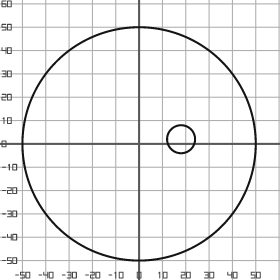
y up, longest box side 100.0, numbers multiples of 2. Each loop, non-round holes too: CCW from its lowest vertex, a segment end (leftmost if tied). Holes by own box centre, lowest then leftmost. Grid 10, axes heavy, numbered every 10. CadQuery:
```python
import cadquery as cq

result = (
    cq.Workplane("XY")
    .moveTo(0.0, 0.0)
    .circle(50.0)
    .moveTo(18.0, 2.0)
    .circle(6.0)
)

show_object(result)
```